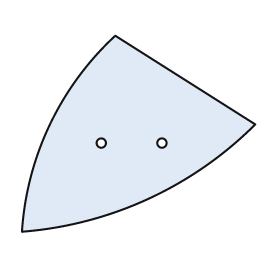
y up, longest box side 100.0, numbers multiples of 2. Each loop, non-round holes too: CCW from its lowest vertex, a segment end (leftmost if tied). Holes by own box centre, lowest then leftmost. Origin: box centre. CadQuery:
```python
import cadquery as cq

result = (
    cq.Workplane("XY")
    .moveTo(-50.0, -42.0)
    .threePointArc((4.0, -28.0), (50.0, 4.0))
    .lineTo(-10.0, 42.0)
    .threePointArc((-38.0, 4.0), (-50.0, -42.0))
    .close()
    .moveTo(-16.0, -4.0)
    .circle(2.0)
    .moveTo(10.0, -4.0)
    .circle(2.0)
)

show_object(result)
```